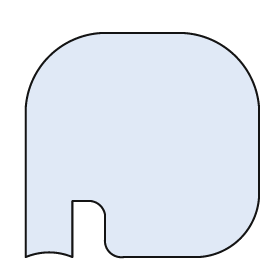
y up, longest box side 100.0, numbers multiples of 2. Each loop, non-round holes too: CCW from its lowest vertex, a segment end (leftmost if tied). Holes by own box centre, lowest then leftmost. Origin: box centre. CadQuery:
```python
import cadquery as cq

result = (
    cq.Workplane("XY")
    .moveTo(-50.0, -48.0)
    .threePointArc((-40.0, -46.0), (-30.0, -48.0))
    .lineTo(-30.0, -24.0)
    .lineTo(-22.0, -24.0)
    .threePointArc((-18.0, -26.0), (-16.0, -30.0))
    .lineTo(-16.0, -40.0)
    .threePointArc((-14.0, -46.0), (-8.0, -48.0))
    .lineTo(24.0, -48.0)
    .threePointArc((42.0, -40.0), (50.0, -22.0))
    .lineTo(50.0, 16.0)
    .threePointArc((40.0, 38.0), (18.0, 48.0))
    .lineTo(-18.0, 48.0)
    .threePointArc((-40.0, 38.0), (-50.0, 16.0))
    .close()
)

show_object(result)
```